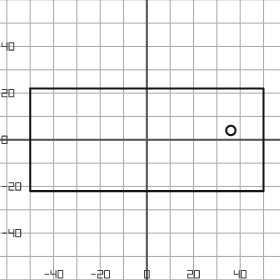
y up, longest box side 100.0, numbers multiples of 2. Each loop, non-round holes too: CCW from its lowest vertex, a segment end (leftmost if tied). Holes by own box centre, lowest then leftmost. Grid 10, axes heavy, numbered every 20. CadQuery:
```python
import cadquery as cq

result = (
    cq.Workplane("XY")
    .moveTo(-50.0, -22.0)
    .lineTo(50.0, -22.0)
    .lineTo(50.0, 22.0)
    .lineTo(-50.0, 22.0)
    .close()
    .moveTo(36.0, 4.0)
    .circle(2.0)
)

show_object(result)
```